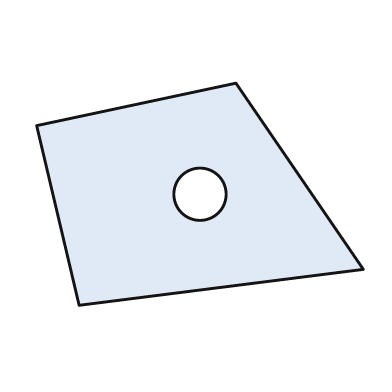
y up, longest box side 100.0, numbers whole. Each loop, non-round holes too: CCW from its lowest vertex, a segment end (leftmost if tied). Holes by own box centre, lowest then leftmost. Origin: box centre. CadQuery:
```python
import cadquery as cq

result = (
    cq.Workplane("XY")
    .moveTo(-37.0, -34.0)
    .lineTo(50.0, -23.0)
    .lineTo(11.0, 34.0)
    .lineTo(-50.0, 21.0)
    .close()
    .moveTo(0.0, 0.0)
    .circle(8.0)
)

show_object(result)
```